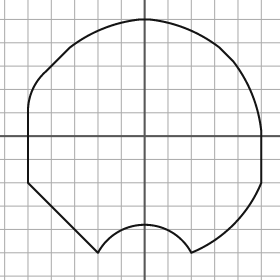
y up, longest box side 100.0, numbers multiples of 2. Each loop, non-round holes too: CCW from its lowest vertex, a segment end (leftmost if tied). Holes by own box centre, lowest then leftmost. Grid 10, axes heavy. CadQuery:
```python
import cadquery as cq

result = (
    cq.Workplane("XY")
    .moveTo(-20.0, -50.0)
    .threePointArc((0.0, -38.0), (20.0, -50.0))
    .threePointArc((38.0, -38.0), (50.0, -20.0))
    .lineTo(50.0, 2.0)
    .threePointArc((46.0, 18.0), (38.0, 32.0))
    .lineTo(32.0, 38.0)
    .threePointArc((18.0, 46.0), (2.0, 50.0))
    .lineTo(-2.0, 50.0)
    .threePointArc((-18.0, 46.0), (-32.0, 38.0))
    .lineTo(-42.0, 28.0)
    .threePointArc((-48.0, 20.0), (-50.0, 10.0))
    .lineTo(-50.0, -20.0)
    .close()
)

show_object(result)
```